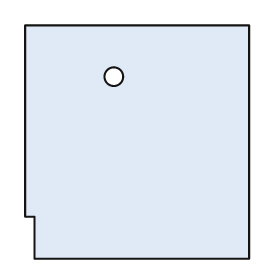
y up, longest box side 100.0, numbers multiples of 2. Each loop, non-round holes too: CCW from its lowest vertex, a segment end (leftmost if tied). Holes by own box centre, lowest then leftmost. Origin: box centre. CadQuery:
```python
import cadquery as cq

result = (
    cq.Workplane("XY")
    .moveTo(-44.0, -50.0)
    .lineTo(48.0, -50.0)
    .lineTo(48.0, 50.0)
    .lineTo(-48.0, 50.0)
    .lineTo(-48.0, -32.0)
    .lineTo(-44.0, -32.0)
    .close()
    .moveTo(-10.0, 28.0)
    .circle(4.0)
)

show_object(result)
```